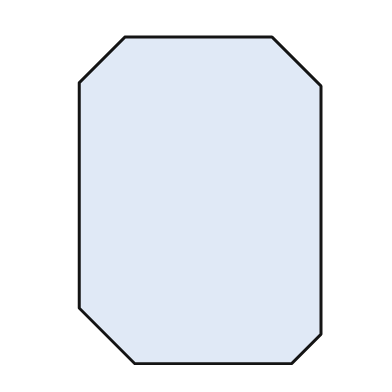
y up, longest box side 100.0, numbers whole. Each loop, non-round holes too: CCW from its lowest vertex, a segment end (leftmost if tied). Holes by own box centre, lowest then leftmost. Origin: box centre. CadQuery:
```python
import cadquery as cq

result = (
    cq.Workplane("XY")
    .moveTo(-20.0, -50.0)
    .lineTo(28.0, -50.0)
    .lineTo(37.0, -41.0)
    .lineTo(37.0, 35.0)
    .lineTo(22.0, 50.0)
    .lineTo(-23.0, 50.0)
    .lineTo(-37.0, 36.0)
    .lineTo(-37.0, -33.0)
    .close()
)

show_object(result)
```